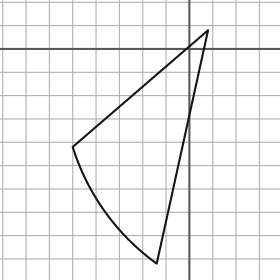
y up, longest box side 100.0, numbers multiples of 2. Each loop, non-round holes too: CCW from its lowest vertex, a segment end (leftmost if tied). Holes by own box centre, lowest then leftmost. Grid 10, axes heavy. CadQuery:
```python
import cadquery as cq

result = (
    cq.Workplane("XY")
    .moveTo(-14.0, -92.0)
    .lineTo(8.0, 8.0)
    .lineTo(-50.0, -42.0)
    .threePointArc((-36.0, -70.0), (-14.0, -92.0))
    .close()
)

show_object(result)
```